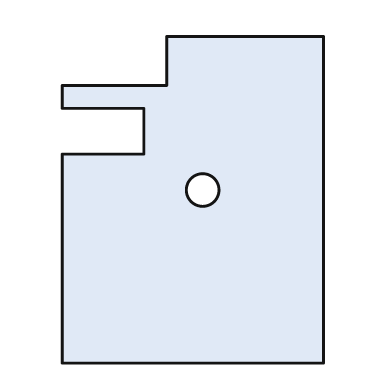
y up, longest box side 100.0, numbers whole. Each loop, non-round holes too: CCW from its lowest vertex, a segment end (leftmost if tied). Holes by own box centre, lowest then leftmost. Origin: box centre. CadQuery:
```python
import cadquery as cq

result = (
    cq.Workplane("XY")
    .moveTo(-40.0, -50.0)
    .lineTo(40.0, -50.0)
    .lineTo(40.0, 50.0)
    .lineTo(-8.0, 50.0)
    .lineTo(-8.0, 35.0)
    .lineTo(-40.0, 35.0)
    .lineTo(-40.0, 28.0)
    .lineTo(-15.0, 28.0)
    .lineTo(-15.0, 14.0)
    .lineTo(-40.0, 14.0)
    .close()
    .moveTo(3.0, 3.0)
    .circle(5.0)
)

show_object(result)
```